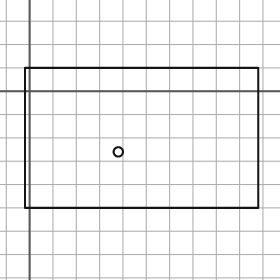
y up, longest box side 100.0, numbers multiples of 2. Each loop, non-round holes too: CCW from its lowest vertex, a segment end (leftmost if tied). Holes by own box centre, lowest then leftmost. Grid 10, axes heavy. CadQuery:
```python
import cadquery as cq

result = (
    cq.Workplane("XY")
    .moveTo(-2.0, -50.0)
    .lineTo(98.0, -50.0)
    .lineTo(98.0, 10.0)
    .lineTo(-2.0, 10.0)
    .close()
    .moveTo(38.0, -26.0)
    .circle(2.0)
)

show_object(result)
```